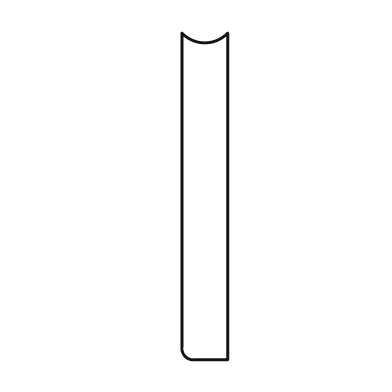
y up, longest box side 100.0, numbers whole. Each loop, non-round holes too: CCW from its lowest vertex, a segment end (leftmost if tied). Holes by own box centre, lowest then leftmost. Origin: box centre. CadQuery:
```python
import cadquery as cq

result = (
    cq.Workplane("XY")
    .moveTo(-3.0, -50.0)
    .lineTo(7.0, -50.0)
    .lineTo(7.0, 50.0)
    .threePointArc((0.0, 47.0), (-7.0, 50.0))
    .lineTo(-7.0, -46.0)
    .threePointArc((-6.0, -49.0), (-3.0, -50.0))
    .close()
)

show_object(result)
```